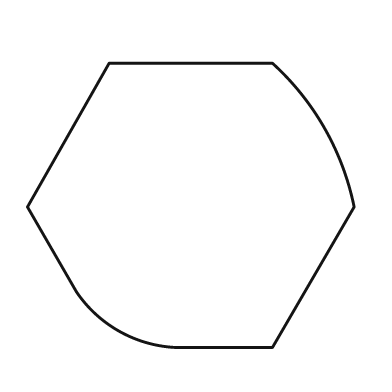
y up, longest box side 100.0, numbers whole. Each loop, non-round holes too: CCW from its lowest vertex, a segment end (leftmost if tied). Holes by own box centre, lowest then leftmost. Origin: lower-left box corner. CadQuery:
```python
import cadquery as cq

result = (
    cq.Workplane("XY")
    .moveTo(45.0, 0.0)
    .lineTo(75.0, 0.0)
    .lineTo(100.0, 43.0)
    .threePointArc((91.0, 67.0), (75.0, 87.0))
    .lineTo(25.0, 87.0)
    .lineTo(0.0, 43.0)
    .lineTo(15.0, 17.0)
    .threePointArc((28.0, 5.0), (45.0, 0.0))
    .close()
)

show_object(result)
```